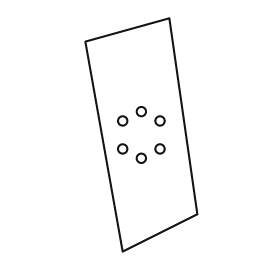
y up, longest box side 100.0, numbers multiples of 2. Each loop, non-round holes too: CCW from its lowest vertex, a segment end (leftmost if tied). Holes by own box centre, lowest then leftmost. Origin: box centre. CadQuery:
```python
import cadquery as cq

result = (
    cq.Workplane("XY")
    .moveTo(-8.0, -50.0)
    .lineTo(24.0, -34.0)
    .lineTo(12.0, 50.0)
    .lineTo(-24.0, 40.0)
    .close()
    .moveTo(0.0, -10.0)
    .circle(2.0)
    .moveTo(-8.0, -6.0)
    .circle(2.0)
    .moveTo(8.0, -6.0)
    .circle(2.0)
    .moveTo(-8.0, 6.0)
    .circle(2.0)
    .moveTo(8.0, 6.0)
    .circle(2.0)
    .moveTo(0.0, 10.0)
    .circle(2.0)
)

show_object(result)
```